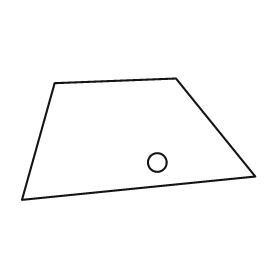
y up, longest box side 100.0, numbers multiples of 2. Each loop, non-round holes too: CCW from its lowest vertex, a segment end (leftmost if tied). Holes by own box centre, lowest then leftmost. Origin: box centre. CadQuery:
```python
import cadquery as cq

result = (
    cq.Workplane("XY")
    .moveTo(-50.0, -26.0)
    .lineTo(50.0, -16.0)
    .lineTo(16.0, 26.0)
    .lineTo(-36.0, 24.0)
    .close()
    .moveTo(8.0, -10.0)
    .circle(4.0)
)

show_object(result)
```